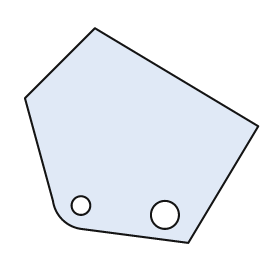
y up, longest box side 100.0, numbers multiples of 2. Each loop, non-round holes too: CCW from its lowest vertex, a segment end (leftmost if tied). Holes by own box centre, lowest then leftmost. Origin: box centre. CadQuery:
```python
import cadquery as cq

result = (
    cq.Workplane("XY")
    .moveTo(20.0, -46.0)
    .lineTo(50.0, 4.0)
    .lineTo(-20.0, 46.0)
    .lineTo(-50.0, 16.0)
    .lineTo(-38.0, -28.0)
    .threePointArc((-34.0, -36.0), (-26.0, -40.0))
    .close()
    .moveTo(10.0, -34.0)
    .circle(6.0)
    .moveTo(-26.0, -30.0)
    .circle(4.0)
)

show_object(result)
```